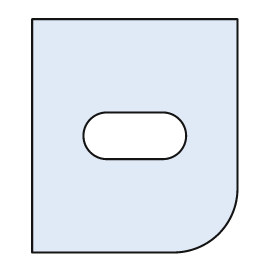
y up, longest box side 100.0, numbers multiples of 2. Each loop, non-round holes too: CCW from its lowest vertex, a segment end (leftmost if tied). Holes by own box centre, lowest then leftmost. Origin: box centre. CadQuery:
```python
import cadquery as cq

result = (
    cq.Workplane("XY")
    .moveTo(-44.0, -50.0)
    .lineTo(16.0, -50.0)
    .threePointArc((36.0, -42.0), (44.0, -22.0))
    .lineTo(44.0, 50.0)
    .lineTo(-44.0, 50.0)
    .close()
    .moveTo(-12.0, -10.0)
    .lineTo(12.0, -10.0)
    .threePointArc((22.0, 0.0), (12.0, 10.0))
    .lineTo(-12.0, 10.0)
    .threePointArc((-22.0, 0.0), (-12.0, -10.0))
    .close()
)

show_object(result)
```